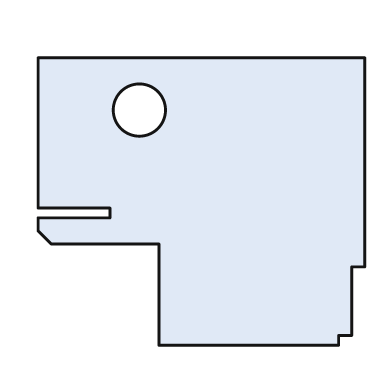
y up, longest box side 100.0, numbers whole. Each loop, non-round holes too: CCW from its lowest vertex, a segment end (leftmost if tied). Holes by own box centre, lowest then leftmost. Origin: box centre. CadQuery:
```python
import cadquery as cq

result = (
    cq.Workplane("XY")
    .moveTo(-13.0, -44.0)
    .lineTo(42.0, -44.0)
    .lineTo(42.0, -41.0)
    .lineTo(46.0, -41.0)
    .lineTo(46.0, -20.0)
    .lineTo(50.0, -20.0)
    .lineTo(50.0, 44.0)
    .lineTo(-50.0, 44.0)
    .lineTo(-50.0, -2.0)
    .lineTo(-28.0, -2.0)
    .lineTo(-28.0, -5.0)
    .lineTo(-50.0, -5.0)
    .lineTo(-50.0, -9.0)
    .lineTo(-46.0, -13.0)
    .lineTo(-13.0, -13.0)
    .close()
    .moveTo(-19.0, 28.0)
    .circle(8.0)
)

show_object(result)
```